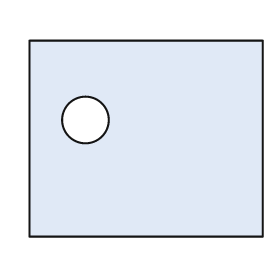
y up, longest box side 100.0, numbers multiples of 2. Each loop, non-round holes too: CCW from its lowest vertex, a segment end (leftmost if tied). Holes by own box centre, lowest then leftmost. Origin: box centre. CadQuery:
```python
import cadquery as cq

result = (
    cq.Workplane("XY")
    .moveTo(-50.0, -42.0)
    .lineTo(50.0, -42.0)
    .lineTo(50.0, 42.0)
    .lineTo(-50.0, 42.0)
    .close()
    .moveTo(-26.0, 8.0)
    .circle(10.0)
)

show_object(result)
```